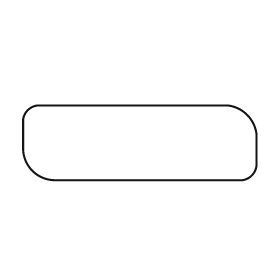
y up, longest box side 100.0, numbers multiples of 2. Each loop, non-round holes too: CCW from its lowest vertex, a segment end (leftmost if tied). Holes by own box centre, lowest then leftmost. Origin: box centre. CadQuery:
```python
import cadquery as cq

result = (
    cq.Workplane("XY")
    .moveTo(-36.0, -16.0)
    .lineTo(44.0, -16.0)
    .threePointArc((48.0, -14.0), (50.0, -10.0))
    .lineTo(50.0, 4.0)
    .threePointArc((46.0, 12.0), (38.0, 16.0))
    .lineTo(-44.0, 16.0)
    .threePointArc((-48.0, 14.0), (-50.0, 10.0))
    .lineTo(-50.0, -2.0)
    .threePointArc((-46.0, -12.0), (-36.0, -16.0))
    .close()
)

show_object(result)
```